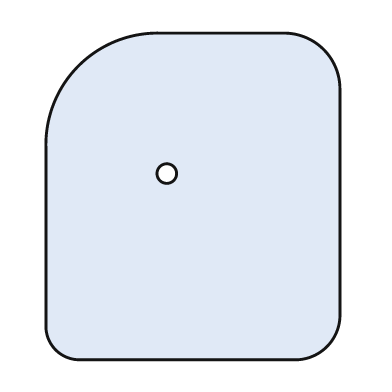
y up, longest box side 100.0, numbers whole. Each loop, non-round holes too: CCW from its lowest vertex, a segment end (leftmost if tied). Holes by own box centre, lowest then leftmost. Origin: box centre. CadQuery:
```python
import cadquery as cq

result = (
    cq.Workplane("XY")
    .moveTo(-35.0, -50.0)
    .lineTo(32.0, -50.0)
    .threePointArc((41.0, -46.0), (45.0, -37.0))
    .lineTo(45.0, 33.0)
    .threePointArc((40.0, 45.0), (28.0, 50.0))
    .lineTo(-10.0, 50.0)
    .threePointArc((-35.0, 40.0), (-45.0, 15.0))
    .lineTo(-45.0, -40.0)
    .threePointArc((-42.0, -47.0), (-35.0, -50.0))
    .close()
    .moveTo(-8.0, 7.0)
    .circle(3.0)
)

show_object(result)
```